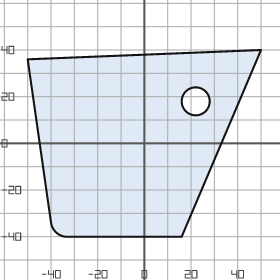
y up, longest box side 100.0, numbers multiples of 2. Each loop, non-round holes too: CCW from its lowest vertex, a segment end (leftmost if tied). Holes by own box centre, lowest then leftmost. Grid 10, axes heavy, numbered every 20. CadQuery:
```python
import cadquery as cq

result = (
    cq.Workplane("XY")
    .moveTo(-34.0, -40.0)
    .lineTo(16.0, -40.0)
    .lineTo(50.0, 40.0)
    .lineTo(-50.0, 36.0)
    .lineTo(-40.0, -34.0)
    .threePointArc((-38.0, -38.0), (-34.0, -40.0))
    .close()
    .moveTo(22.0, 18.0)
    .circle(6.0)
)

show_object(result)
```